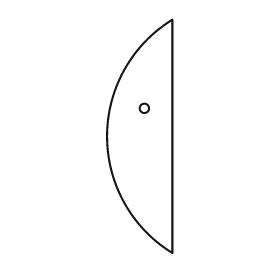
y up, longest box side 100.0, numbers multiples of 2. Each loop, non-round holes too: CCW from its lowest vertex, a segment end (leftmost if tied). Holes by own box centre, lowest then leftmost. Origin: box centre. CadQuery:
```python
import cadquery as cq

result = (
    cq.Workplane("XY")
    .moveTo(14.0, -50.0)
    .lineTo(14.0, 50.0)
    .threePointArc((-14.0, 0.0), (14.0, -50.0))
    .close()
    .moveTo(2.0, 12.0)
    .circle(2.0)
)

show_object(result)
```